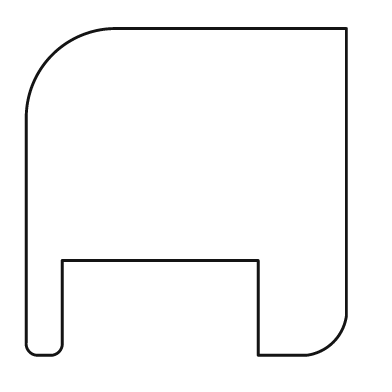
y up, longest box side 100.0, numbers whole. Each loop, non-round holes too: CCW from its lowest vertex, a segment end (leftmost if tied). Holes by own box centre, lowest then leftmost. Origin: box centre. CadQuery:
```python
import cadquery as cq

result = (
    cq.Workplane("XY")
    .moveTo(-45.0, -50.0)
    .lineTo(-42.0, -50.0)
    .threePointArc((-39.0, -49.0), (-38.0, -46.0))
    .lineTo(-38.0, -21.0)
    .lineTo(22.0, -21.0)
    .lineTo(22.0, -50.0)
    .lineTo(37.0, -50.0)
    .threePointArc((45.0, -46.0), (49.0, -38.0))
    .lineTo(49.0, 50.0)
    .lineTo(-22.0, 50.0)
    .threePointArc((-41.0, 42.0), (-49.0, 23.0))
    .lineTo(-49.0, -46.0)
    .threePointArc((-48.0, -49.0), (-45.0, -50.0))
    .close()
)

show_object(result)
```